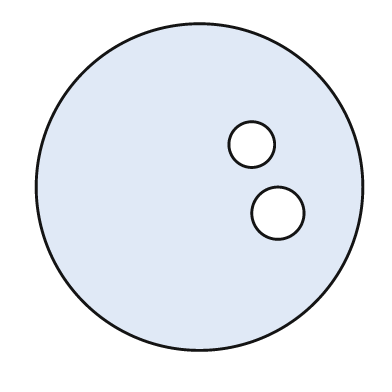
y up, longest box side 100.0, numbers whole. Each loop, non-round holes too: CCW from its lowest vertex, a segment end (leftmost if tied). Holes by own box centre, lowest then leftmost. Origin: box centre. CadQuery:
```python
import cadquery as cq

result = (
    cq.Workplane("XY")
    .moveTo(0.0, 0.0)
    .circle(50.0)
    .moveTo(24.0, -8.0)
    .circle(8.0)
    .moveTo(16.0, 13.0)
    .circle(7.0)
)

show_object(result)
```